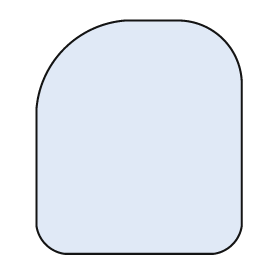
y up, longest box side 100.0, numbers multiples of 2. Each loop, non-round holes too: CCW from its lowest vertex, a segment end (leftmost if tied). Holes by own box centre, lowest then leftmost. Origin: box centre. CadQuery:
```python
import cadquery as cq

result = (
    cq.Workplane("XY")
    .moveTo(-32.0, -50.0)
    .lineTo(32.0, -50.0)
    .threePointArc((40.0, -46.0), (44.0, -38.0))
    .lineTo(44.0, 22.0)
    .threePointArc((36.0, 42.0), (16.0, 50.0))
    .lineTo(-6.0, 50.0)
    .threePointArc((-32.0, 38.0), (-44.0, 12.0))
    .lineTo(-44.0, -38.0)
    .threePointArc((-40.0, -46.0), (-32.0, -50.0))
    .close()
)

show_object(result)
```